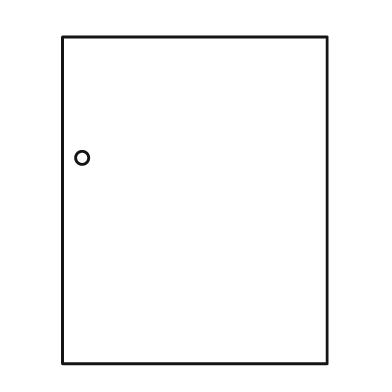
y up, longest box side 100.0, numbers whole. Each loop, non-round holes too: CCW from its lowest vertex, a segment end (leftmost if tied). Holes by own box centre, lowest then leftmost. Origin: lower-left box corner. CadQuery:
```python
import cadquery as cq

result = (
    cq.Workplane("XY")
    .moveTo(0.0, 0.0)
    .lineTo(81.0, 0.0)
    .lineTo(81.0, 100.0)
    .lineTo(0.0, 100.0)
    .close()
    .moveTo(6.0, 63.0)
    .circle(2.0)
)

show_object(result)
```